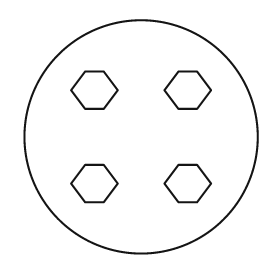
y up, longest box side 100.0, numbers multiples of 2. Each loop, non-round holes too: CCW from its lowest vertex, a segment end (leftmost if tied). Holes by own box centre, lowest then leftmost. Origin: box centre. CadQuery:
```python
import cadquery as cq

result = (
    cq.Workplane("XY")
    .moveTo(0.0, 0.0)
    .circle(50.0)
    .moveTo(-24.0, -28.0)
    .lineTo(-16.0, -28.0)
    .lineTo(-10.0, -20.0)
    .lineTo(-16.0, -12.0)
    .lineTo(-24.0, -12.0)
    .lineTo(-30.0, -20.0)
    .close()
    .moveTo(16.0, -28.0)
    .lineTo(24.0, -28.0)
    .lineTo(30.0, -20.0)
    .lineTo(24.0, -12.0)
    .lineTo(16.0, -12.0)
    .lineTo(10.0, -20.0)
    .close()
    .moveTo(-24.0, 12.0)
    .lineTo(-16.0, 12.0)
    .lineTo(-10.0, 20.0)
    .lineTo(-16.0, 28.0)
    .lineTo(-24.0, 28.0)
    .lineTo(-30.0, 20.0)
    .close()
    .moveTo(16.0, 12.0)
    .lineTo(24.0, 12.0)
    .lineTo(30.0, 20.0)
    .lineTo(24.0, 28.0)
    .lineTo(16.0, 28.0)
    .lineTo(10.0, 20.0)
    .close()
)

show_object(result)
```